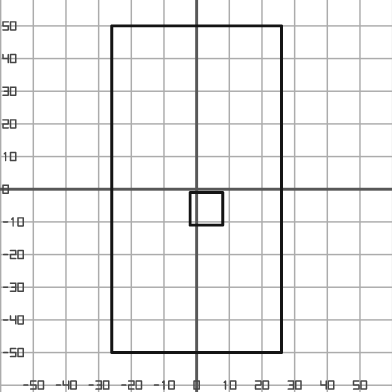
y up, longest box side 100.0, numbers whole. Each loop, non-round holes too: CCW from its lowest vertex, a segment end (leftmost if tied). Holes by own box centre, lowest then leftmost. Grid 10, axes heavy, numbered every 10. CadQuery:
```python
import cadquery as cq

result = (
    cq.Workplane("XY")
    .moveTo(-26.0, -50.0)
    .lineTo(26.0, -50.0)
    .lineTo(26.0, 50.0)
    .lineTo(-26.0, 50.0)
    .close()
    .moveTo(-2.0, -11.0)
    .lineTo(8.0, -11.0)
    .lineTo(8.0, -1.0)
    .lineTo(-2.0, -1.0)
    .close()
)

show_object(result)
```